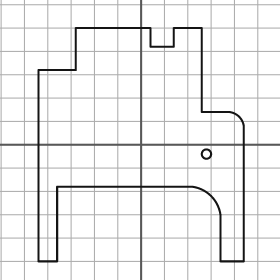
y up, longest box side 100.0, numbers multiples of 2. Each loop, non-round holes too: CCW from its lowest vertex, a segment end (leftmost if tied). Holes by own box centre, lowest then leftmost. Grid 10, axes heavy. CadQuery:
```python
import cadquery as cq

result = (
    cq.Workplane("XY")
    .moveTo(-44.0, -50.0)
    .lineTo(-36.0, -50.0)
    .lineTo(-36.0, -18.0)
    .lineTo(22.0, -18.0)
    .threePointArc((30.0, -22.0), (34.0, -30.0))
    .lineTo(34.0, -50.0)
    .lineTo(44.0, -50.0)
    .lineTo(44.0, 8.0)
    .threePointArc((42.0, 12.0), (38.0, 14.0))
    .lineTo(26.0, 14.0)
    .lineTo(26.0, 50.0)
    .lineTo(14.0, 50.0)
    .lineTo(14.0, 42.0)
    .lineTo(4.0, 42.0)
    .lineTo(4.0, 50.0)
    .lineTo(-28.0, 50.0)
    .lineTo(-28.0, 32.0)
    .lineTo(-44.0, 32.0)
    .close()
    .moveTo(28.0, -4.0)
    .circle(2.0)
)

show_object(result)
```